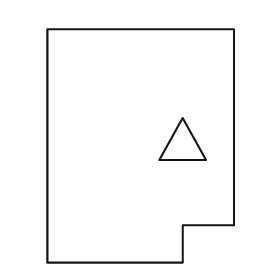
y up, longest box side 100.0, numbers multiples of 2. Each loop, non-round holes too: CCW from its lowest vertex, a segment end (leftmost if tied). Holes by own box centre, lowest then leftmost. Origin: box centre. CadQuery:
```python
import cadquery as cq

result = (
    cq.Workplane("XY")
    .moveTo(-40.0, -50.0)
    .lineTo(18.0, -50.0)
    .lineTo(18.0, -34.0)
    .lineTo(40.0, -34.0)
    .lineTo(40.0, 50.0)
    .lineTo(-40.0, 50.0)
    .close()
    .moveTo(8.0, -6.0)
    .lineTo(28.0, -6.0)
    .lineTo(18.0, 12.0)
    .close()
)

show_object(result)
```